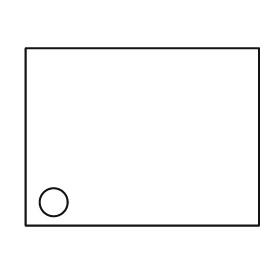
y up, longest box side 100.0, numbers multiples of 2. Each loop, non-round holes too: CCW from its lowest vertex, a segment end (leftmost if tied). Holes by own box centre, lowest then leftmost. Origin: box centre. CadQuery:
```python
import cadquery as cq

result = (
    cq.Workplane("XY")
    .moveTo(-50.0, -38.0)
    .lineTo(50.0, -38.0)
    .lineTo(50.0, 38.0)
    .lineTo(-50.0, 38.0)
    .close()
    .moveTo(-38.0, -28.0)
    .circle(6.0)
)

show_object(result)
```